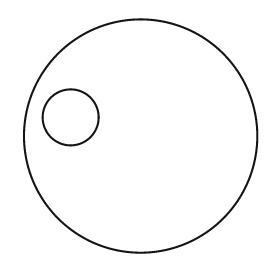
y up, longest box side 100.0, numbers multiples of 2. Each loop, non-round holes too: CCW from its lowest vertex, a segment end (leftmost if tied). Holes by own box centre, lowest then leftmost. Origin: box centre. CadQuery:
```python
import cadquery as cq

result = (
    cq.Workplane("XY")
    .moveTo(0.0, 0.0)
    .circle(50.0)
    .moveTo(-30.0, 8.0)
    .circle(12.0)
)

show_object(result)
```